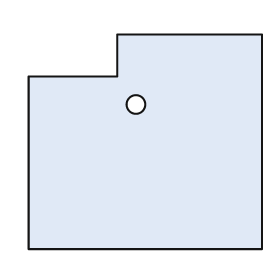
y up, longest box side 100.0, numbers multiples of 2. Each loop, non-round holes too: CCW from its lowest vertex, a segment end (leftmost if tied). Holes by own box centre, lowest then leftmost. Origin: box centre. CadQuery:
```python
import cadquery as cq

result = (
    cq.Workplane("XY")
    .moveTo(-50.0, -46.0)
    .lineTo(50.0, -46.0)
    .lineTo(50.0, 46.0)
    .lineTo(-12.0, 46.0)
    .lineTo(-12.0, 28.0)
    .lineTo(-50.0, 28.0)
    .close()
    .moveTo(-4.0, 16.0)
    .circle(4.0)
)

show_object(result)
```